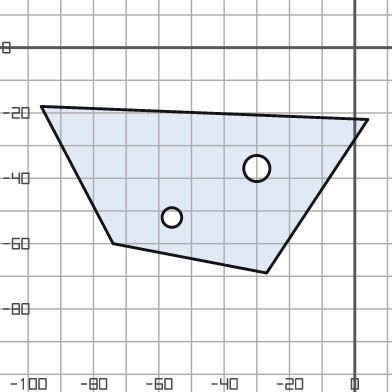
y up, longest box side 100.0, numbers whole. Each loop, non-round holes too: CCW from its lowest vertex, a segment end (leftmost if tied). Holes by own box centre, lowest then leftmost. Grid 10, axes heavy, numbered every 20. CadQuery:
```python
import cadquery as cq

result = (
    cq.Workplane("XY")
    .moveTo(-27.0, -69.0)
    .lineTo(4.0, -22.0)
    .lineTo(-96.0, -18.0)
    .lineTo(-74.0, -60.0)
    .close()
    .moveTo(-56.0, -52.0)
    .circle(3.0)
    .moveTo(-30.0, -37.0)
    .circle(4.0)
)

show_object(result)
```